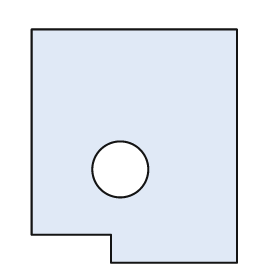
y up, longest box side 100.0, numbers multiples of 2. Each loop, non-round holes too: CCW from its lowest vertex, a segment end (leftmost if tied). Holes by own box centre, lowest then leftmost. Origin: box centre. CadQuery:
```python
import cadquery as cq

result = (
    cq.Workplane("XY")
    .moveTo(-10.0, -50.0)
    .lineTo(44.0, -50.0)
    .lineTo(44.0, 50.0)
    .lineTo(-44.0, 50.0)
    .lineTo(-44.0, -38.0)
    .lineTo(-10.0, -38.0)
    .close()
    .moveTo(-6.0, -10.0)
    .circle(12.0)
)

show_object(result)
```